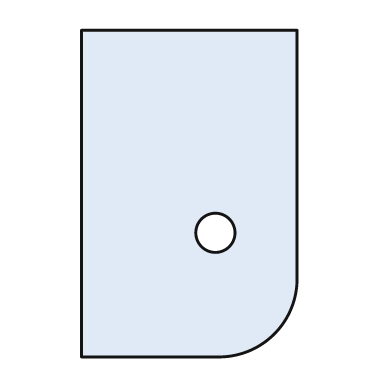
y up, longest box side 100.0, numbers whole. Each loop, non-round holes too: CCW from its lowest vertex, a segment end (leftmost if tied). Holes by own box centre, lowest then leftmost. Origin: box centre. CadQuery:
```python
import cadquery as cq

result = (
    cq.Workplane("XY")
    .moveTo(-33.0, -50.0)
    .lineTo(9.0, -50.0)
    .threePointArc((26.0, -43.0), (33.0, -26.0))
    .lineTo(33.0, 50.0)
    .lineTo(-33.0, 50.0)
    .close()
    .moveTo(8.0, -12.0)
    .circle(6.0)
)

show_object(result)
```